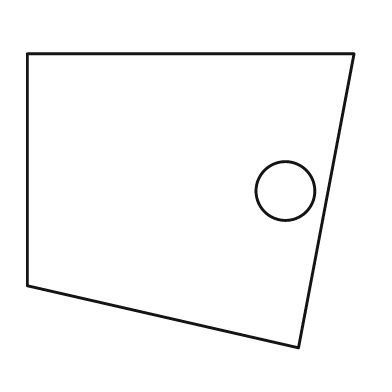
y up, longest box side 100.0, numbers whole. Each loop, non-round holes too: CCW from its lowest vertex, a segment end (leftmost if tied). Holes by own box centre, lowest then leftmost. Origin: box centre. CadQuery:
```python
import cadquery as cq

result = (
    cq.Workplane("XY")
    .moveTo(33.0, -45.0)
    .lineTo(50.0, 45.0)
    .lineTo(-50.0, 45.0)
    .lineTo(-50.0, -26.0)
    .close()
    .moveTo(29.0, 3.0)
    .circle(9.0)
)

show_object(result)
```